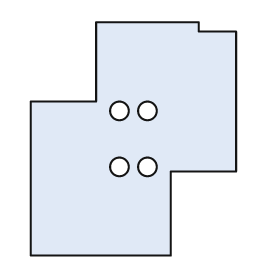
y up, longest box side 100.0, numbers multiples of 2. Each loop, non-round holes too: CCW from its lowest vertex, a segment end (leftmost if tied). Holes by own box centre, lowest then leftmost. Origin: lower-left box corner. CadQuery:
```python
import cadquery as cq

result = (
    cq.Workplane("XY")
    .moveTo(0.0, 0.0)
    .lineTo(60.0, 0.0)
    .lineTo(60.0, 36.0)
    .lineTo(88.0, 36.0)
    .lineTo(88.0, 96.0)
    .lineTo(72.0, 96.0)
    .lineTo(72.0, 100.0)
    .lineTo(28.0, 100.0)
    .lineTo(28.0, 66.0)
    .lineTo(0.0, 66.0)
    .close()
    .moveTo(38.0, 38.0)
    .circle(4.0)
    .moveTo(50.0, 38.0)
    .circle(4.0)
    .moveTo(38.0, 62.0)
    .circle(4.0)
    .moveTo(50.0, 62.0)
    .circle(4.0)
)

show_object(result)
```